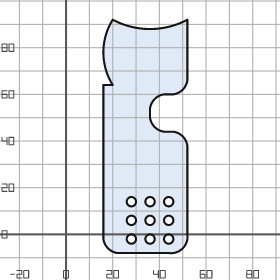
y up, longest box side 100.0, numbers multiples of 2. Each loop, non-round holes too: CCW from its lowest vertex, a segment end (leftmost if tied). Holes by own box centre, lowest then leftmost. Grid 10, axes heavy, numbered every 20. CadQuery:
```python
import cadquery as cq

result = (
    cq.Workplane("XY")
    .moveTo(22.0, -8.0)
    .lineTo(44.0, -8.0)
    .threePointArc((50.0, -6.0), (52.0, 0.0))
    .lineTo(52.0, 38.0)
    .threePointArc((50.0, 42.0), (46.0, 44.0))
    .lineTo(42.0, 44.0)
    .threePointArc((38.0, 46.0), (36.0, 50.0))
    .lineTo(36.0, 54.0)
    .threePointArc((38.0, 58.0), (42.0, 60.0))
    .lineTo(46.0, 60.0)
    .threePointArc((50.0, 62.0), (52.0, 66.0))
    .lineTo(52.0, 92.0)
    .threePointArc((36.0, 88.0), (20.0, 92.0))
    .threePointArc((16.0, 78.0), (20.0, 64.0))
    .lineTo(16.0, 64.0)
    .lineTo(16.0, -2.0)
    .threePointArc((18.0, -6.0), (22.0, -8.0))
    .close()
    .moveTo(28.0, -2.0)
    .circle(2.0)
    .moveTo(36.0, -2.0)
    .circle(2.0)
    .moveTo(44.0, -2.0)
    .circle(2.0)
    .moveTo(28.0, 6.0)
    .circle(2.0)
    .moveTo(36.0, 6.0)
    .circle(2.0)
    .moveTo(44.0, 6.0)
    .circle(2.0)
    .moveTo(28.0, 14.0)
    .circle(2.0)
    .moveTo(36.0, 14.0)
    .circle(2.0)
    .moveTo(44.0, 14.0)
    .circle(2.0)
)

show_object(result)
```